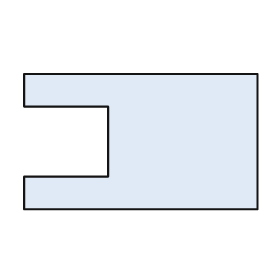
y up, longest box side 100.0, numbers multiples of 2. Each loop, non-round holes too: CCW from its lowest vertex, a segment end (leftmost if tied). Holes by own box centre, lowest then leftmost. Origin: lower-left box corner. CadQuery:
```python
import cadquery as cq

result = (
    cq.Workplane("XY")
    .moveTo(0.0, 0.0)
    .lineTo(100.0, 0.0)
    .lineTo(100.0, 58.0)
    .lineTo(0.0, 58.0)
    .lineTo(0.0, 44.0)
    .lineTo(36.0, 44.0)
    .lineTo(36.0, 14.0)
    .lineTo(0.0, 14.0)
    .close()
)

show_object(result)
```